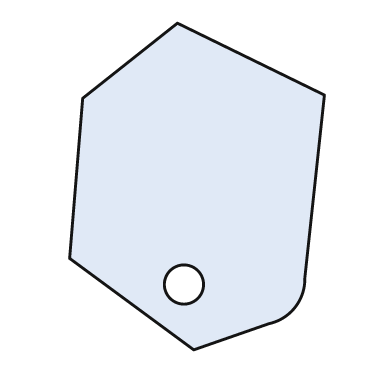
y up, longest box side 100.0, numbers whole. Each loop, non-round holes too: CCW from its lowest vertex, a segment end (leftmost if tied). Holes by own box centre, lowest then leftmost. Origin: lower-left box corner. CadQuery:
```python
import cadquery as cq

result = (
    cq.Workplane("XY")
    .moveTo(38.0, 0.0)
    .lineTo(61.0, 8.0)
    .threePointArc((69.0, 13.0), (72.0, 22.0))
    .lineTo(78.0, 78.0)
    .lineTo(33.0, 100.0)
    .lineTo(4.0, 77.0)
    .lineTo(0.0, 28.0)
    .close()
    .moveTo(35.0, 20.0)
    .circle(6.0)
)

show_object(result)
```